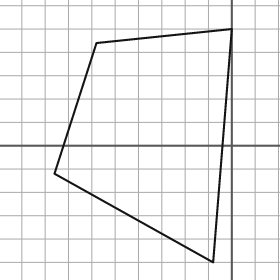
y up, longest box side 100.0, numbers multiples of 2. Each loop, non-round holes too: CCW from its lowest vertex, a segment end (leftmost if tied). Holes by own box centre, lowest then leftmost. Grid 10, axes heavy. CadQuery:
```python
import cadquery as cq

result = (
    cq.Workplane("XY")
    .moveTo(-8.0, -50.0)
    .lineTo(0.0, 50.0)
    .lineTo(-58.0, 44.0)
    .lineTo(-76.0, -12.0)
    .close()
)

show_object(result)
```